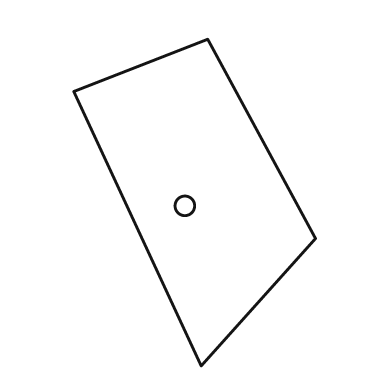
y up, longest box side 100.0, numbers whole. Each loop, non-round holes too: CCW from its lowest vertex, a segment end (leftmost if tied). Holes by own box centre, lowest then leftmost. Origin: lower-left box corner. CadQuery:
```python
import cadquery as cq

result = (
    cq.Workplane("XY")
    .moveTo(39.0, 0.0)
    .lineTo(74.0, 39.0)
    .lineTo(41.0, 100.0)
    .lineTo(0.0, 84.0)
    .close()
    .moveTo(34.0, 49.0)
    .circle(3.0)
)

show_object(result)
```